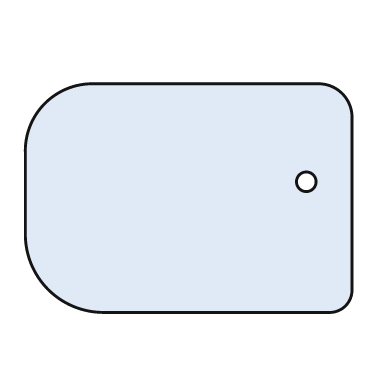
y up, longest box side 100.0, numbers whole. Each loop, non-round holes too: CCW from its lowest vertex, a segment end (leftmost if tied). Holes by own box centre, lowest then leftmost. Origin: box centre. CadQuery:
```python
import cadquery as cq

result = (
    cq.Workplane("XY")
    .moveTo(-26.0, -35.0)
    .lineTo(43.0, -35.0)
    .threePointArc((48.0, -33.0), (50.0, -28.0))
    .lineTo(50.0, 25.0)
    .threePointArc((47.0, 32.0), (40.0, 35.0))
    .lineTo(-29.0, 35.0)
    .threePointArc((-44.0, 29.0), (-50.0, 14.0))
    .lineTo(-50.0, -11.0)
    .threePointArc((-43.0, -28.0), (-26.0, -35.0))
    .close()
    .moveTo(36.0, 5.0)
    .circle(3.0)
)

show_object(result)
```